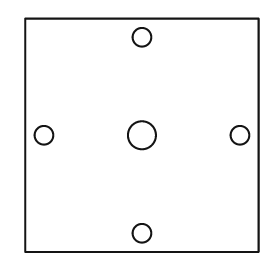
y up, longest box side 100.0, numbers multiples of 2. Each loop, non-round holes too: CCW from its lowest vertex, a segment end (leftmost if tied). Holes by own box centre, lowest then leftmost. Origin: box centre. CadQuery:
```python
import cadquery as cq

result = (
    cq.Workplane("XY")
    .moveTo(-50.0, -50.0)
    .lineTo(50.0, -50.0)
    .lineTo(50.0, 50.0)
    .lineTo(-50.0, 50.0)
    .close()
    .moveTo(0.0, -42.0)
    .circle(4.0)
    .moveTo(-42.0, 0.0)
    .circle(4.0)
    .moveTo(0.0, 0.0)
    .circle(6.0)
    .moveTo(42.0, 0.0)
    .circle(4.0)
    .moveTo(0.0, 42.0)
    .circle(4.0)
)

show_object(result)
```